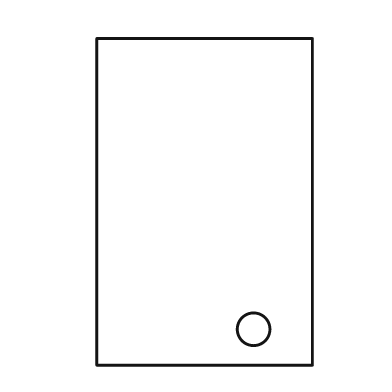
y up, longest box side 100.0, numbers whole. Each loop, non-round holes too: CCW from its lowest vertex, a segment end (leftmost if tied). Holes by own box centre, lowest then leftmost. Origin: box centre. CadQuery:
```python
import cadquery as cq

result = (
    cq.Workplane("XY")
    .moveTo(-33.0, -50.0)
    .lineTo(33.0, -50.0)
    .lineTo(33.0, 50.0)
    .lineTo(-33.0, 50.0)
    .close()
    .moveTo(15.0, -39.0)
    .circle(5.0)
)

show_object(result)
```